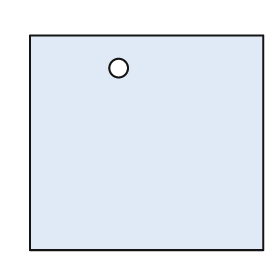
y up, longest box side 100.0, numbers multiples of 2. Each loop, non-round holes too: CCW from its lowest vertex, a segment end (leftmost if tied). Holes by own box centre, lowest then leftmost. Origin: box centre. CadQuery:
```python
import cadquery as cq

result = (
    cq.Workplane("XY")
    .moveTo(-50.0, -46.0)
    .lineTo(50.0, -46.0)
    .lineTo(50.0, 46.0)
    .lineTo(-50.0, 46.0)
    .close()
    .moveTo(-12.0, 32.0)
    .circle(4.0)
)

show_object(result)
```